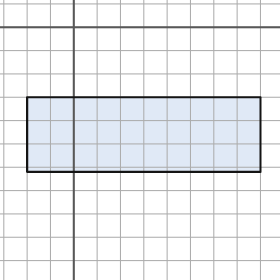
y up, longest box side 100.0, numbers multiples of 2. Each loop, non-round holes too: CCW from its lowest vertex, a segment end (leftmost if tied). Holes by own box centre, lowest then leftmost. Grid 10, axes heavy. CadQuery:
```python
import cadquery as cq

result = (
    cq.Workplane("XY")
    .moveTo(-20.0, -62.0)
    .lineTo(80.0, -62.0)
    .lineTo(80.0, -30.0)
    .lineTo(-20.0, -30.0)
    .close()
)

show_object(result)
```